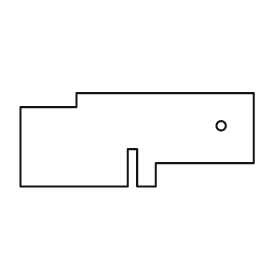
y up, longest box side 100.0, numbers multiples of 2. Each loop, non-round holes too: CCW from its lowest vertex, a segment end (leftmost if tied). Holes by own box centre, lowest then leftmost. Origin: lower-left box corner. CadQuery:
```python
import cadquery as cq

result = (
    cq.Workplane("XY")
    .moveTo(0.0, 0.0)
    .lineTo(46.0, 0.0)
    .lineTo(46.0, 16.0)
    .lineTo(50.0, 16.0)
    .lineTo(50.0, 0.0)
    .lineTo(58.0, 0.0)
    .lineTo(58.0, 10.0)
    .lineTo(100.0, 10.0)
    .lineTo(100.0, 40.0)
    .lineTo(24.0, 40.0)
    .lineTo(24.0, 34.0)
    .lineTo(0.0, 34.0)
    .close()
    .moveTo(86.0, 26.0)
    .circle(2.0)
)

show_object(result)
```